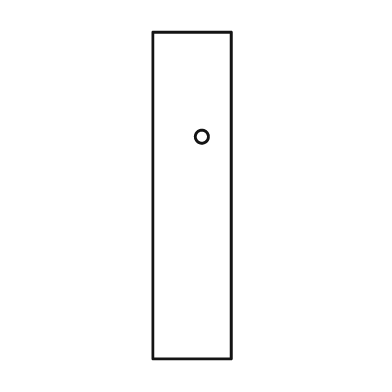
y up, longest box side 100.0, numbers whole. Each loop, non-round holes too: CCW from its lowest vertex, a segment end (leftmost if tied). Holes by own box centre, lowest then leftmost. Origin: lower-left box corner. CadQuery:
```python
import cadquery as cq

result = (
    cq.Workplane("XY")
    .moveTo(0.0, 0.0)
    .lineTo(24.0, 0.0)
    .lineTo(24.0, 100.0)
    .lineTo(0.0, 100.0)
    .close()
    .moveTo(15.0, 68.0)
    .circle(2.0)
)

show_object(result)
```